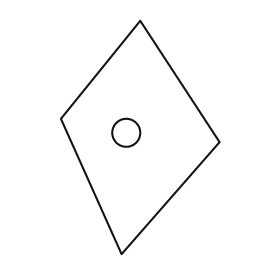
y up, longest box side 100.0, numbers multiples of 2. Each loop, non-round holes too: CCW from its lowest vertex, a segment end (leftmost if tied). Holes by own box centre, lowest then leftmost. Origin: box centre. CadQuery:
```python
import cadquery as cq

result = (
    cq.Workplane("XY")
    .moveTo(-8.0, -50.0)
    .lineTo(34.0, -2.0)
    .lineTo(0.0, 50.0)
    .lineTo(-34.0, 8.0)
    .close()
    .moveTo(-6.0, 2.0)
    .circle(6.0)
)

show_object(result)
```